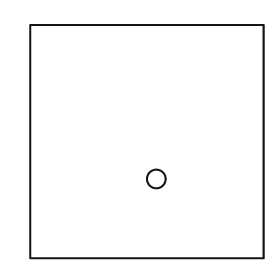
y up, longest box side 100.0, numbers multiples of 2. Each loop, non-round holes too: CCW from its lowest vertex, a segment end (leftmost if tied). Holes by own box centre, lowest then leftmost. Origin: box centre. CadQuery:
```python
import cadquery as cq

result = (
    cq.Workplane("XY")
    .moveTo(-50.0, -50.0)
    .lineTo(50.0, -50.0)
    .lineTo(50.0, 50.0)
    .lineTo(-50.0, 50.0)
    .close()
    .moveTo(4.0, -16.0)
    .circle(4.0)
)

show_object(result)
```